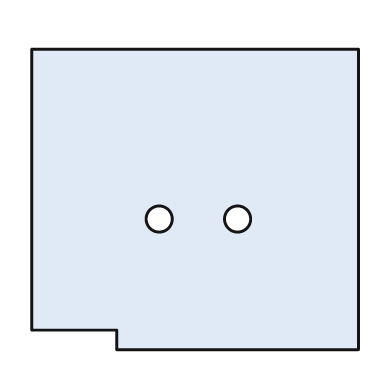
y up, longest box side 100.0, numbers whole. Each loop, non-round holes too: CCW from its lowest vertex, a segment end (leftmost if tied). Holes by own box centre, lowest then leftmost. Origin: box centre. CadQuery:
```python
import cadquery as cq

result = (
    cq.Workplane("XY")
    .moveTo(-24.0, -46.0)
    .lineTo(50.0, -46.0)
    .lineTo(50.0, 46.0)
    .lineTo(-50.0, 46.0)
    .lineTo(-50.0, -40.0)
    .lineTo(-24.0, -40.0)
    .close()
    .moveTo(-11.0, -6.0)
    .circle(4.0)
    .moveTo(13.0, -6.0)
    .circle(4.0)
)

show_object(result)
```